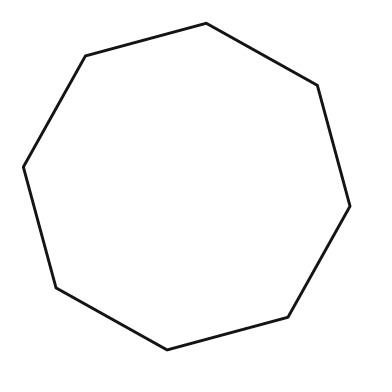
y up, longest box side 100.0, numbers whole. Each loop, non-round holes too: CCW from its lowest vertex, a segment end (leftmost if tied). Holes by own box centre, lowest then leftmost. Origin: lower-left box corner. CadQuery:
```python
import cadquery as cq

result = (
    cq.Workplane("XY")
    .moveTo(44.0, 0.0)
    .lineTo(81.0, 10.0)
    .lineTo(100.0, 44.0)
    .lineTo(90.0, 81.0)
    .lineTo(56.0, 100.0)
    .lineTo(19.0, 90.0)
    .lineTo(0.0, 56.0)
    .lineTo(10.0, 19.0)
    .close()
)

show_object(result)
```